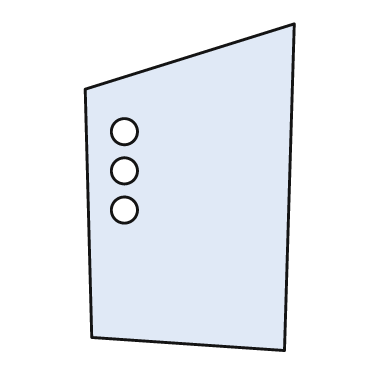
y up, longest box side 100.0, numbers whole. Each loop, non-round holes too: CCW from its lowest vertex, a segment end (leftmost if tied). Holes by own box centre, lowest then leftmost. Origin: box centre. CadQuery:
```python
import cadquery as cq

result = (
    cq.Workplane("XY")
    .moveTo(29.0, -50.0)
    .lineTo(32.0, 50.0)
    .lineTo(-32.0, 30.0)
    .lineTo(-30.0, -46.0)
    .close()
    .moveTo(-20.0, -7.0)
    .circle(4.0)
    .moveTo(-20.0, 5.0)
    .circle(4.0)
    .moveTo(-20.0, 17.0)
    .circle(4.0)
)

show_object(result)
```